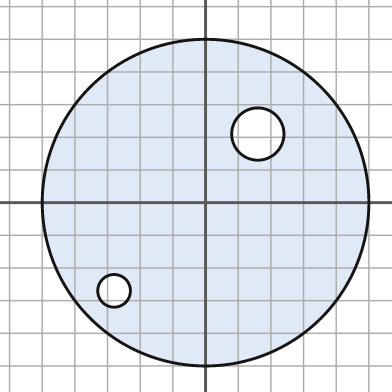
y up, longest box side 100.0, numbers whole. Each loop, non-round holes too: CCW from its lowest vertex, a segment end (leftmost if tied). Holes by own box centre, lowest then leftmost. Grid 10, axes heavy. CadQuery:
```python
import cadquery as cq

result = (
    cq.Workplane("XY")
    .moveTo(0.0, 0.0)
    .circle(50.0)
    .moveTo(-28.0, -27.0)
    .circle(5.0)
    .moveTo(16.0, 21.0)
    .circle(8.0)
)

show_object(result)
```